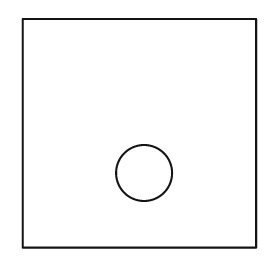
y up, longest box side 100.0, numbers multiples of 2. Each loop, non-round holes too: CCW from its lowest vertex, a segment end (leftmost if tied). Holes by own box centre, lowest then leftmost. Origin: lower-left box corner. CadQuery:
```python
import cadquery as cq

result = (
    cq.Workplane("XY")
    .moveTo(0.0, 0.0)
    .lineTo(100.0, 0.0)
    .lineTo(100.0, 98.0)
    .lineTo(0.0, 98.0)
    .close()
    .moveTo(52.0, 32.0)
    .circle(12.0)
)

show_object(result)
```